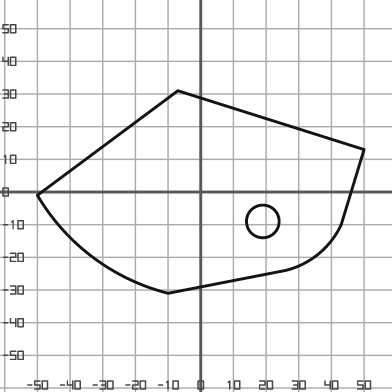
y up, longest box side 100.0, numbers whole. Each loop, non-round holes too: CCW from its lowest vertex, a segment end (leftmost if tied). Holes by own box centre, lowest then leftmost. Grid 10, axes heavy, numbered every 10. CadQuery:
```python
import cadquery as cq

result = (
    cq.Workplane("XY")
    .moveTo(-10.0, -31.0)
    .lineTo(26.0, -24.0)
    .threePointArc((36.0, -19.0), (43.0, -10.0))
    .lineTo(50.0, 13.0)
    .lineTo(-7.0, 31.0)
    .lineTo(-50.0, -1.0)
    .threePointArc((-33.0, -20.0), (-10.0, -31.0))
    .close()
    .moveTo(19.0, -9.0)
    .circle(5.0)
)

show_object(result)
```